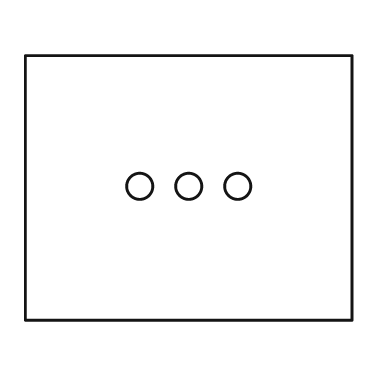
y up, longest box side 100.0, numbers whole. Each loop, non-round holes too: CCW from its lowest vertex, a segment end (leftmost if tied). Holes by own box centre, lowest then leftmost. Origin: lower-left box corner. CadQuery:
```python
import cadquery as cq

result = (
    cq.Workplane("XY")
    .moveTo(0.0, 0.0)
    .lineTo(100.0, 0.0)
    .lineTo(100.0, 81.0)
    .lineTo(0.0, 81.0)
    .close()
    .moveTo(35.0, 41.0)
    .circle(4.0)
    .moveTo(50.0, 41.0)
    .circle(4.0)
    .moveTo(65.0, 41.0)
    .circle(4.0)
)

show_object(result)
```